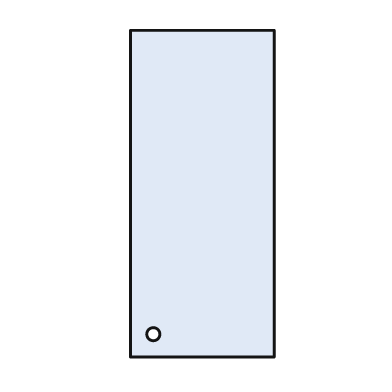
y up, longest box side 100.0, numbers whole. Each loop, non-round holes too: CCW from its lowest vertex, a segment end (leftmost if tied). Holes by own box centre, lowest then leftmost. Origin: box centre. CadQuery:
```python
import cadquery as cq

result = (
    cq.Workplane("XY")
    .moveTo(-22.0, -50.0)
    .lineTo(22.0, -50.0)
    .lineTo(22.0, 50.0)
    .lineTo(-22.0, 50.0)
    .close()
    .moveTo(-15.0, -43.0)
    .circle(2.0)
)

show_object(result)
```